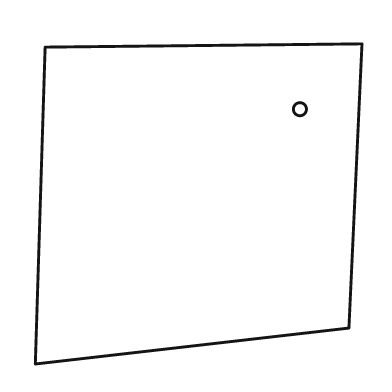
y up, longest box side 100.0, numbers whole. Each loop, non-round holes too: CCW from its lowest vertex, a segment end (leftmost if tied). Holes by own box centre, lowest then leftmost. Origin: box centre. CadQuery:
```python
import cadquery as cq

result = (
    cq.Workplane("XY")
    .moveTo(-50.0, -49.0)
    .lineTo(46.0, -38.0)
    .lineTo(50.0, 49.0)
    .lineTo(-47.0, 48.0)
    .close()
    .moveTo(31.0, 29.0)
    .circle(2.0)
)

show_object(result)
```